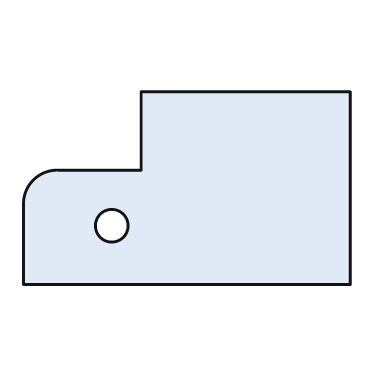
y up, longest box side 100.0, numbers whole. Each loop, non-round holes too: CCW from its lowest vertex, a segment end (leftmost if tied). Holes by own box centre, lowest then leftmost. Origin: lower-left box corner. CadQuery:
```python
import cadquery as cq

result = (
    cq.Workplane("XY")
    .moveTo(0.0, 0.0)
    .lineTo(100.0, 0.0)
    .lineTo(100.0, 59.0)
    .lineTo(36.0, 59.0)
    .lineTo(36.0, 35.0)
    .lineTo(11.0, 35.0)
    .threePointArc((3.0, 32.0), (0.0, 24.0))
    .close()
    .moveTo(27.0, 18.0)
    .circle(5.0)
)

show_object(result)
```